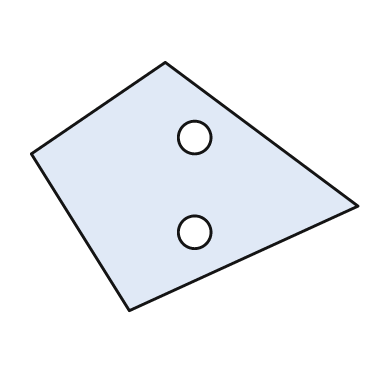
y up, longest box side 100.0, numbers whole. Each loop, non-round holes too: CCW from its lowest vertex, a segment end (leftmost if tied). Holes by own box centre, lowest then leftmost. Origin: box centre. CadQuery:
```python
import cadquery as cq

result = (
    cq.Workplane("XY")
    .moveTo(-20.0, -38.0)
    .lineTo(50.0, -6.0)
    .lineTo(-9.0, 38.0)
    .lineTo(-50.0, 10.0)
    .close()
    .moveTo(0.0, -14.0)
    .circle(5.0)
    .moveTo(0.0, 15.0)
    .circle(5.0)
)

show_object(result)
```